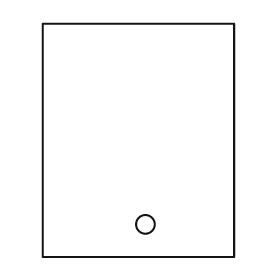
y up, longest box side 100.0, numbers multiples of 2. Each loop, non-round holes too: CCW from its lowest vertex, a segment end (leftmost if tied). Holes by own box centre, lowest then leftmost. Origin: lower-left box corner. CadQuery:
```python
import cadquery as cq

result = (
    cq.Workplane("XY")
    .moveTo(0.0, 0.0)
    .lineTo(82.0, 0.0)
    .lineTo(82.0, 100.0)
    .lineTo(0.0, 100.0)
    .close()
    .moveTo(44.0, 14.0)
    .circle(4.0)
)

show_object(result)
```